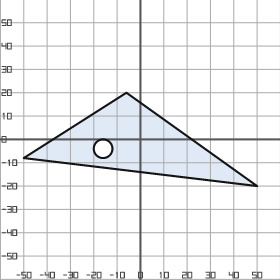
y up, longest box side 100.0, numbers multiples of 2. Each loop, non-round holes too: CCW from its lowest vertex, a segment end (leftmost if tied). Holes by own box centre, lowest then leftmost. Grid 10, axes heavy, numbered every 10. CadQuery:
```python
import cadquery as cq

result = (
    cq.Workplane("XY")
    .moveTo(50.0, -20.0)
    .lineTo(-6.0, 20.0)
    .lineTo(-50.0, -8.0)
    .close()
    .moveTo(-16.0, -4.0)
    .circle(4.0)
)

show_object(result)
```